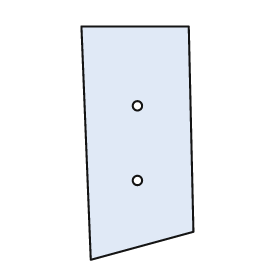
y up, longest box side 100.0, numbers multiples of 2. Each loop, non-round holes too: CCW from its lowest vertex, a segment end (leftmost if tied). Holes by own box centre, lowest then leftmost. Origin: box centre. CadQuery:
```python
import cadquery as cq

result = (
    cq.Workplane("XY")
    .moveTo(-20.0, -50.0)
    .lineTo(24.0, -38.0)
    .lineTo(22.0, 50.0)
    .lineTo(-24.0, 50.0)
    .close()
    .moveTo(0.0, -16.0)
    .circle(2.0)
    .moveTo(0.0, 16.0)
    .circle(2.0)
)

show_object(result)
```